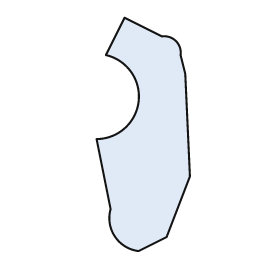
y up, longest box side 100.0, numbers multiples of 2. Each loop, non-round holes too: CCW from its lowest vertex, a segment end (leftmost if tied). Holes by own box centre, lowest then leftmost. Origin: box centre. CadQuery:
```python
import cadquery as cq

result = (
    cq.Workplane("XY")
    .moveTo(-2.0, -50.0)
    .lineTo(10.0, -44.0)
    .lineTo(20.0, -18.0)
    .lineTo(18.0, 26.0)
    .lineTo(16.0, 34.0)
    .threePointArc((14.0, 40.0), (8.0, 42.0))
    .lineTo(-8.0, 50.0)
    .lineTo(-16.0, 34.0)
    .threePointArc((-2.0, 14.0), (-20.0, -2.0))
    .lineTo(-14.0, -32.0)
    .threePointArc((-12.0, -44.0), (-2.0, -50.0))
    .close()
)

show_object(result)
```